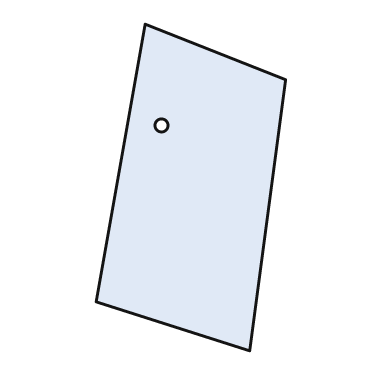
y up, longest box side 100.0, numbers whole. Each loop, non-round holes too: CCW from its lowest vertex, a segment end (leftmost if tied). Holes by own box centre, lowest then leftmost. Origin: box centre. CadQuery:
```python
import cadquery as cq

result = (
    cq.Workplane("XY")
    .moveTo(18.0, -50.0)
    .lineTo(29.0, 33.0)
    .lineTo(-14.0, 50.0)
    .lineTo(-29.0, -35.0)
    .close()
    .moveTo(-9.0, 19.0)
    .circle(2.0)
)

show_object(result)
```